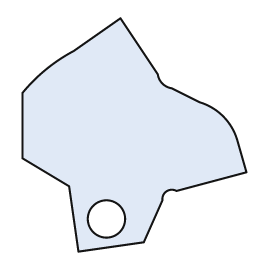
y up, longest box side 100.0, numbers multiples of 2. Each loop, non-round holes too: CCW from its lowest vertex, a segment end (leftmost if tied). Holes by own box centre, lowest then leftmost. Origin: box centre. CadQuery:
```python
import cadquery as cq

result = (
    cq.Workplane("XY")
    .moveTo(-24.0, -50.0)
    .lineTo(4.0, -46.0)
    .lineTo(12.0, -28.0)
    .threePointArc((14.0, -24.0), (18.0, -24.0))
    .lineTo(48.0, -16.0)
    .lineTo(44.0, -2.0)
    .threePointArc((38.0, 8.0), (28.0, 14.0))
    .lineTo(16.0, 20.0)
    .threePointArc((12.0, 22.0), (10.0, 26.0))
    .lineTo(-6.0, 50.0)
    .lineTo(-26.0, 36.0)
    .threePointArc((-38.0, 28.0), (-48.0, 18.0))
    .lineTo(-48.0, -10.0)
    .lineTo(-28.0, -22.0)
    .close()
    .moveTo(-12.0, -36.0)
    .circle(8.0)
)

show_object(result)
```